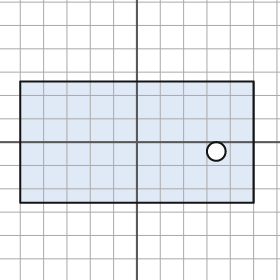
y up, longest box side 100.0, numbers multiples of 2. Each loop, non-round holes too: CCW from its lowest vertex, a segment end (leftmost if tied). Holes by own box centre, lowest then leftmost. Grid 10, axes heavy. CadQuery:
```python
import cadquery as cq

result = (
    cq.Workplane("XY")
    .moveTo(-50.0, -26.0)
    .lineTo(50.0, -26.0)
    .lineTo(50.0, 26.0)
    .lineTo(-50.0, 26.0)
    .close()
    .moveTo(34.0, -4.0)
    .circle(4.0)
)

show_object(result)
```